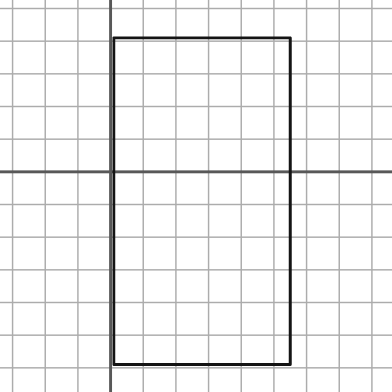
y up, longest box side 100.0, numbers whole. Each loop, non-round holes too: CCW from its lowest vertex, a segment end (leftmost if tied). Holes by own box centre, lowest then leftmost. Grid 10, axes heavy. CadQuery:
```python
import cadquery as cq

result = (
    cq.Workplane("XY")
    .moveTo(1.0, -59.0)
    .lineTo(55.0, -59.0)
    .lineTo(55.0, 41.0)
    .lineTo(1.0, 41.0)
    .close()
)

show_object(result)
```